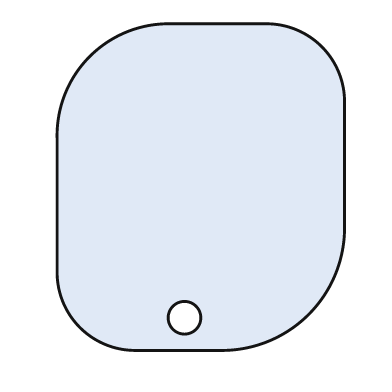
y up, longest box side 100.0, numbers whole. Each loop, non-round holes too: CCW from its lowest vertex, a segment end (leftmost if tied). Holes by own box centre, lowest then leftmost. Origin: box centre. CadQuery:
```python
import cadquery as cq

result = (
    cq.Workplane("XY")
    .moveTo(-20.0, -50.0)
    .lineTo(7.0, -50.0)
    .threePointArc((33.0, -39.0), (44.0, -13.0))
    .lineTo(44.0, 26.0)
    .threePointArc((37.0, 43.0), (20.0, 50.0))
    .lineTo(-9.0, 50.0)
    .threePointArc((-34.0, 40.0), (-44.0, 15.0))
    .lineTo(-44.0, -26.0)
    .threePointArc((-37.0, -43.0), (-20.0, -50.0))
    .close()
    .moveTo(-5.0, -40.0)
    .circle(5.0)
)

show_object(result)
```